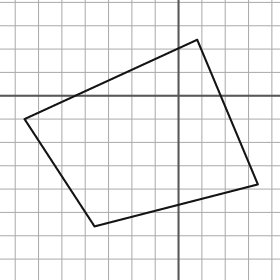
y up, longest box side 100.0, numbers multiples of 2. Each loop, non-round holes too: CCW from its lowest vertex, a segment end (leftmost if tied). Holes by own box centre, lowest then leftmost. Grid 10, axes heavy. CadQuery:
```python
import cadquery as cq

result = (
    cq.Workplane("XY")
    .moveTo(-36.0, -56.0)
    .lineTo(34.0, -38.0)
    .lineTo(8.0, 24.0)
    .lineTo(-66.0, -10.0)
    .close()
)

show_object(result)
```